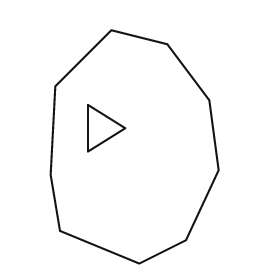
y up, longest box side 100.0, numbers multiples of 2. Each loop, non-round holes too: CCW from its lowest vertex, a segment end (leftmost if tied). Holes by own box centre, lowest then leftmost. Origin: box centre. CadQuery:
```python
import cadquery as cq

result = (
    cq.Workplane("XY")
    .moveTo(2.0, -50.0)
    .lineTo(22.0, -40.0)
    .lineTo(36.0, -10.0)
    .lineTo(32.0, 20.0)
    .lineTo(14.0, 44.0)
    .lineTo(-10.0, 50.0)
    .lineTo(-34.0, 26.0)
    .lineTo(-36.0, -12.0)
    .lineTo(-32.0, -36.0)
    .close()
    .moveTo(-20.0, -2.0)
    .lineTo(-4.0, 8.0)
    .lineTo(-20.0, 18.0)
    .close()
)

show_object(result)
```